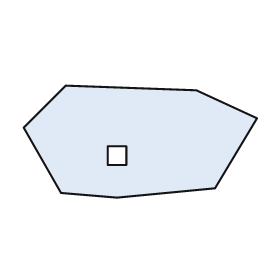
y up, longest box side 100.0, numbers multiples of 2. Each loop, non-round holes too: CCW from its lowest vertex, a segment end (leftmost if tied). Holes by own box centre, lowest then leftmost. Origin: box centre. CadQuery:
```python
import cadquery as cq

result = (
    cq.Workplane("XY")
    .moveTo(-10.0, -24.0)
    .lineTo(32.0, -20.0)
    .lineTo(50.0, 10.0)
    .lineTo(24.0, 22.0)
    .lineTo(-32.0, 24.0)
    .lineTo(-50.0, 6.0)
    .lineTo(-34.0, -22.0)
    .close()
    .moveTo(-14.0, -10.0)
    .lineTo(-6.0, -10.0)
    .lineTo(-6.0, -2.0)
    .lineTo(-14.0, -2.0)
    .close()
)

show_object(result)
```